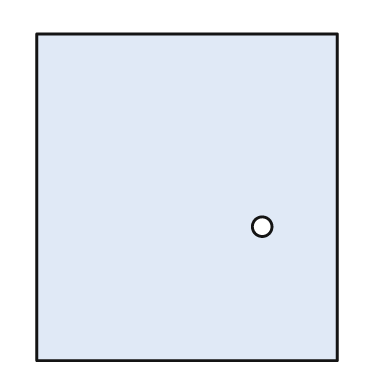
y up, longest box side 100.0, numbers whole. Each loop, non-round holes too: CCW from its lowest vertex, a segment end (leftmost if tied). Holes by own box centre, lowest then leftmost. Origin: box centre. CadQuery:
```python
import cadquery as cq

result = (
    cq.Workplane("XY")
    .moveTo(-46.0, -50.0)
    .lineTo(46.0, -50.0)
    .lineTo(46.0, 50.0)
    .lineTo(-46.0, 50.0)
    .close()
    .moveTo(23.0, -9.0)
    .circle(3.0)
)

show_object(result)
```